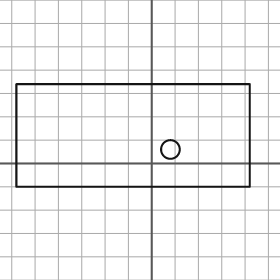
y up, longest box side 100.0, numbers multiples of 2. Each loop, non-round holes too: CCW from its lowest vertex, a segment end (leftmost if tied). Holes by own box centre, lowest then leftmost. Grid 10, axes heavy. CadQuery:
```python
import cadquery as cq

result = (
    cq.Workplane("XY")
    .moveTo(-58.0, -10.0)
    .lineTo(42.0, -10.0)
    .lineTo(42.0, 34.0)
    .lineTo(-58.0, 34.0)
    .close()
    .moveTo(8.0, 6.0)
    .circle(4.0)
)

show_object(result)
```